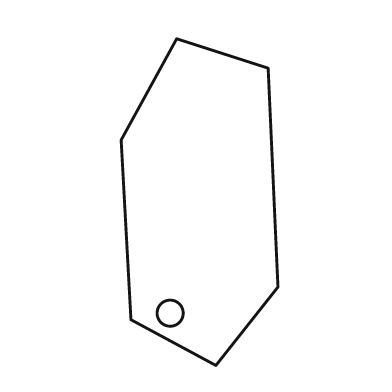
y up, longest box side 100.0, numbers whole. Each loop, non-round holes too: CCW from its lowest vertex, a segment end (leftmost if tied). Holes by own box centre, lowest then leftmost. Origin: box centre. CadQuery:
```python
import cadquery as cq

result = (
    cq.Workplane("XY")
    .moveTo(5.0, -50.0)
    .lineTo(24.0, -26.0)
    .lineTo(21.0, 41.0)
    .lineTo(-7.0, 50.0)
    .lineTo(-24.0, 19.0)
    .lineTo(-21.0, -36.0)
    .close()
    .moveTo(-9.0, -34.0)
    .circle(4.0)
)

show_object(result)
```